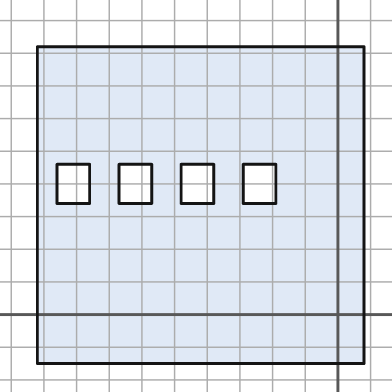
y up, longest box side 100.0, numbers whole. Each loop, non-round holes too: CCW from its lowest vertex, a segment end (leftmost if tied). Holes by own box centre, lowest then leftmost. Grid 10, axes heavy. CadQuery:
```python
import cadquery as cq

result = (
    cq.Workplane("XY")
    .moveTo(-92.0, -15.0)
    .lineTo(8.0, -15.0)
    .lineTo(8.0, 82.0)
    .lineTo(-92.0, 82.0)
    .close()
    .moveTo(-86.0, 34.0)
    .lineTo(-76.0, 34.0)
    .lineTo(-76.0, 46.0)
    .lineTo(-86.0, 46.0)
    .close()
    .moveTo(-67.0, 34.0)
    .lineTo(-57.0, 34.0)
    .lineTo(-57.0, 46.0)
    .lineTo(-67.0, 46.0)
    .close()
    .moveTo(-48.0, 34.0)
    .lineTo(-38.0, 34.0)
    .lineTo(-38.0, 46.0)
    .lineTo(-48.0, 46.0)
    .close()
    .moveTo(-29.0, 34.0)
    .lineTo(-19.0, 34.0)
    .lineTo(-19.0, 46.0)
    .lineTo(-29.0, 46.0)
    .close()
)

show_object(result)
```